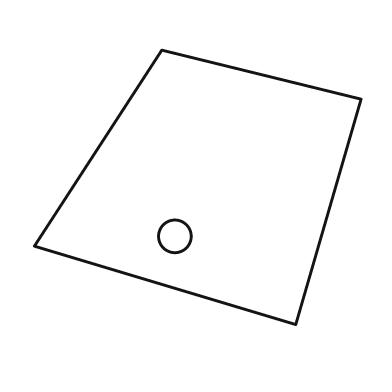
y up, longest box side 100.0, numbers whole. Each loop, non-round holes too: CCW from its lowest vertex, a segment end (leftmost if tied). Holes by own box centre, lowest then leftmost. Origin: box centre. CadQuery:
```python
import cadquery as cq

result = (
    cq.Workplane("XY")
    .moveTo(30.0, -42.0)
    .lineTo(50.0, 27.0)
    .lineTo(-11.0, 42.0)
    .lineTo(-50.0, -18.0)
    .close()
    .moveTo(-7.0, -15.0)
    .circle(5.0)
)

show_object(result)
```